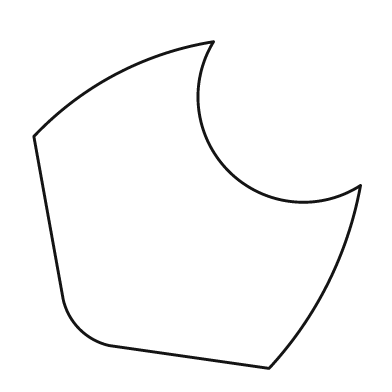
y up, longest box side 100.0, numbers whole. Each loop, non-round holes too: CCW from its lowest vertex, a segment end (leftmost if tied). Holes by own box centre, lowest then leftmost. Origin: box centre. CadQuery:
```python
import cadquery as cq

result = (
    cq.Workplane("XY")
    .moveTo(22.0, -50.0)
    .threePointArc((40.0, -24.0), (50.0, 6.0))
    .threePointArc((10.0, 10.0), (5.0, 50.0))
    .threePointArc((-25.0, 40.0), (-50.0, 21.0))
    .lineTo(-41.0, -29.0)
    .threePointArc((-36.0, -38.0), (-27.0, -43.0))
    .close()
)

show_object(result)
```